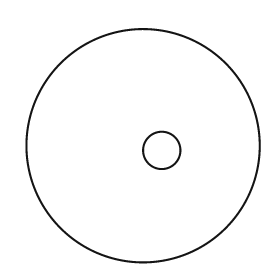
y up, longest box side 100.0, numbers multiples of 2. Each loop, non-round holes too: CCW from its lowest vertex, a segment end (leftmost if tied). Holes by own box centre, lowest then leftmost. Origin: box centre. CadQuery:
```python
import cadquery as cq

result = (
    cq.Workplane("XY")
    .moveTo(0.0, 0.0)
    .circle(50.0)
    .moveTo(8.0, -2.0)
    .circle(8.0)
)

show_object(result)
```